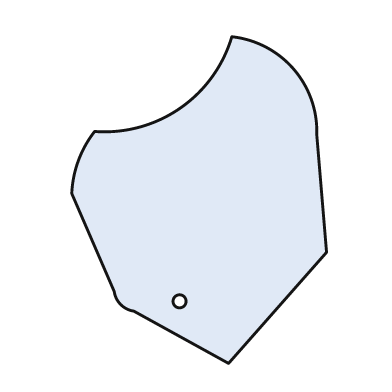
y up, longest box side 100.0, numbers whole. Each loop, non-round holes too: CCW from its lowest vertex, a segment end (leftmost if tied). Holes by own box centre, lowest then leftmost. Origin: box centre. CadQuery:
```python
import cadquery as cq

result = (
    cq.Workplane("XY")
    .moveTo(9.0, -50.0)
    .lineTo(39.0, -16.0)
    .lineTo(36.0, 20.0)
    .threePointArc((29.0, 40.0), (10.0, 50.0))
    .threePointArc((-6.0, 28.0), (-32.0, 21.0))
    .threePointArc((-37.0, 12.0), (-39.0, 2.0))
    .lineTo(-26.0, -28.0)
    .threePointArc((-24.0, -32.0), (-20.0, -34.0))
    .close()
    .moveTo(-6.0, -31.0)
    .circle(2.0)
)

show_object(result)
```